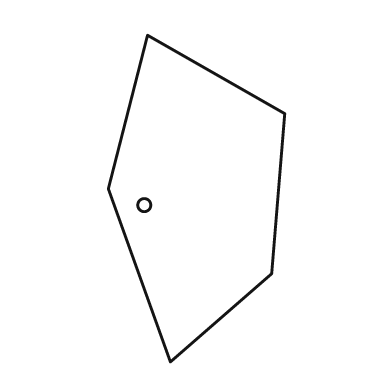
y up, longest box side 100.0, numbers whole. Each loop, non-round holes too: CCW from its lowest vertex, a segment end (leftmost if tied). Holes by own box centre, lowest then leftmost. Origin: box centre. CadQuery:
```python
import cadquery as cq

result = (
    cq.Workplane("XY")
    .moveTo(-8.0, -50.0)
    .lineTo(23.0, -23.0)
    .lineTo(27.0, 26.0)
    .lineTo(-15.0, 50.0)
    .lineTo(-27.0, 3.0)
    .close()
    .moveTo(-16.0, -2.0)
    .circle(2.0)
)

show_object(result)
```